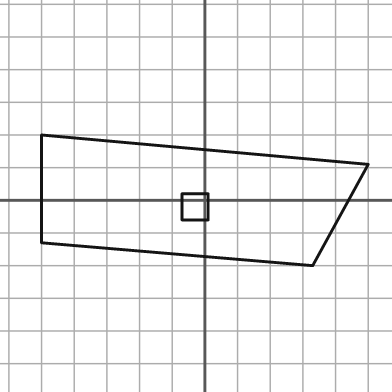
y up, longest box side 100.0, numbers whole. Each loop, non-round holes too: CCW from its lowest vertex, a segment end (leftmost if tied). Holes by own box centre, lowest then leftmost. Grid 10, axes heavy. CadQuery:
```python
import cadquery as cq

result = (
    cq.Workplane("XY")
    .moveTo(33.0, -20.0)
    .lineTo(50.0, 11.0)
    .lineTo(-50.0, 20.0)
    .lineTo(-50.0, -13.0)
    .close()
    .moveTo(-7.0, -6.0)
    .lineTo(1.0, -6.0)
    .lineTo(1.0, 2.0)
    .lineTo(-7.0, 2.0)
    .close()
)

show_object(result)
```